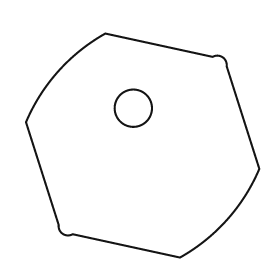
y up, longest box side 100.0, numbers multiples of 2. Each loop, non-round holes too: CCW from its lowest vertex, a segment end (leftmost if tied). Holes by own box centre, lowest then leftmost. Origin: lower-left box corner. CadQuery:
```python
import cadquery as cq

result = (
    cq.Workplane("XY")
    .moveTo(66.0, 0.0)
    .threePointArc((86.0, 16.0), (100.0, 38.0))
    .lineTo(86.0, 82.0)
    .threePointArc((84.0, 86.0), (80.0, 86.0))
    .lineTo(34.0, 96.0)
    .threePointArc((14.0, 80.0), (0.0, 58.0))
    .lineTo(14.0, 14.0)
    .threePointArc((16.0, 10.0), (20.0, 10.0))
    .close()
    .moveTo(46.0, 64.0)
    .circle(8.0)
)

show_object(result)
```